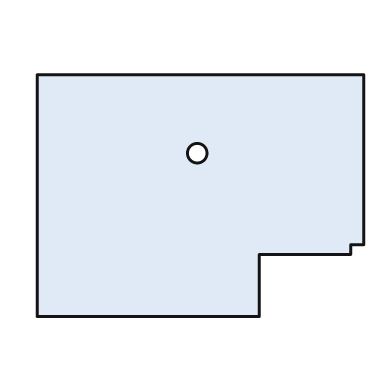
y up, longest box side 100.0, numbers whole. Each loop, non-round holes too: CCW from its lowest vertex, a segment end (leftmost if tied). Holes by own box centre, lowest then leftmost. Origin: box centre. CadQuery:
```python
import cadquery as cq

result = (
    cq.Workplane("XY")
    .moveTo(-50.0, -37.0)
    .lineTo(18.0, -37.0)
    .lineTo(18.0, -18.0)
    .lineTo(46.0, -18.0)
    .lineTo(46.0, -15.0)
    .lineTo(50.0, -15.0)
    .lineTo(50.0, 37.0)
    .lineTo(-50.0, 37.0)
    .close()
    .moveTo(-1.0, 13.0)
    .circle(3.0)
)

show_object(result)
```